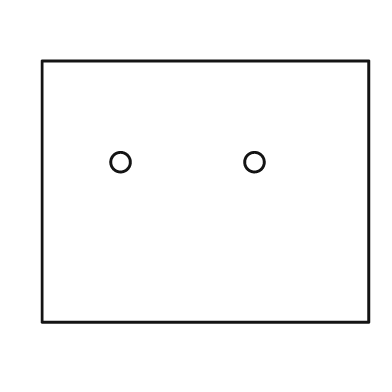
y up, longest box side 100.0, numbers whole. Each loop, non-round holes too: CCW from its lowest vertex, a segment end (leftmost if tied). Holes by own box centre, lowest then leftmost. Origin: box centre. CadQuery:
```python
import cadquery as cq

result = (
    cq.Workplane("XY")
    .moveTo(-50.0, -40.0)
    .lineTo(50.0, -40.0)
    .lineTo(50.0, 40.0)
    .lineTo(-50.0, 40.0)
    .close()
    .moveTo(-26.0, 9.0)
    .circle(3.0)
    .moveTo(15.0, 9.0)
    .circle(3.0)
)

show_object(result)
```